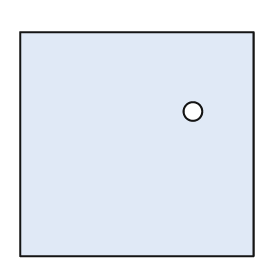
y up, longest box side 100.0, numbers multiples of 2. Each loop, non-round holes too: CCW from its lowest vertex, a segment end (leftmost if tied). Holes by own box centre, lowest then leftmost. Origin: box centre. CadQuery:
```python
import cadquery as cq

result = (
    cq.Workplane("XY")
    .moveTo(-50.0, -48.0)
    .lineTo(50.0, -48.0)
    .lineTo(50.0, 48.0)
    .lineTo(-50.0, 48.0)
    .close()
    .moveTo(24.0, 14.0)
    .circle(4.0)
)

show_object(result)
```